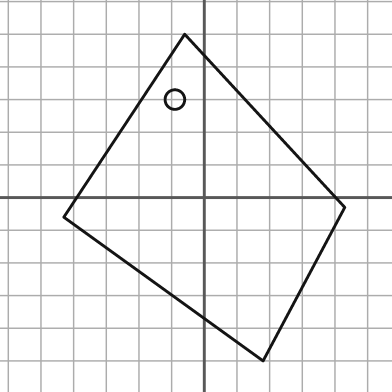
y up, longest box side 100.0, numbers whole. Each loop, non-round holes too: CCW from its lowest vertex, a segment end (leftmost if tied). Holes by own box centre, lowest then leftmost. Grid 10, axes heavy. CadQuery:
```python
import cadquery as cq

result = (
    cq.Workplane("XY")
    .moveTo(18.0, -50.0)
    .lineTo(43.0, -3.0)
    .lineTo(-6.0, 50.0)
    .lineTo(-43.0, -6.0)
    .close()
    .moveTo(-9.0, 30.0)
    .circle(3.0)
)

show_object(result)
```